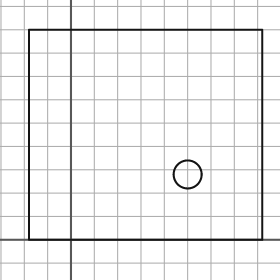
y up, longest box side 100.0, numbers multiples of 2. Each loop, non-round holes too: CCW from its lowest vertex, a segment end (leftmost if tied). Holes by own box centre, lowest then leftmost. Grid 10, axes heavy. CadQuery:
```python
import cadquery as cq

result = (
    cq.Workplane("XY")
    .moveTo(-18.0, 0.0)
    .lineTo(82.0, 0.0)
    .lineTo(82.0, 90.0)
    .lineTo(-18.0, 90.0)
    .close()
    .moveTo(50.0, 28.0)
    .circle(6.0)
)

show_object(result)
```